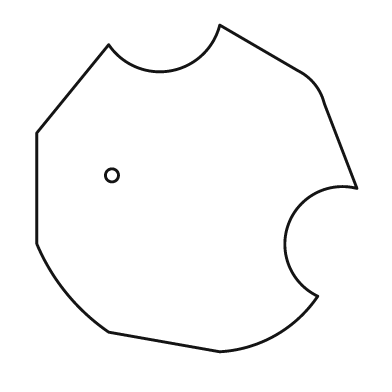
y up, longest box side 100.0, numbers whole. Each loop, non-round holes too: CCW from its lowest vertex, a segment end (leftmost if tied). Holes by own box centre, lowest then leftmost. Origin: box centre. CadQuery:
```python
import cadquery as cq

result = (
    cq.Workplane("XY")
    .moveTo(7.0, -50.0)
    .threePointArc((24.0, -45.0), (37.0, -33.0))
    .threePointArc((28.0, -11.0), (49.0, 0.0))
    .lineTo(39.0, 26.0)
    .threePointArc((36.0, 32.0), (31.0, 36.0))
    .lineTo(7.0, 50.0)
    .threePointArc((-8.0, 36.0), (-27.0, 44.0))
    .lineTo(-49.0, 17.0)
    .lineTo(-49.0, -17.0)
    .threePointArc((-40.0, -32.0), (-27.0, -44.0))
    .close()
    .moveTo(-26.0, 4.0)
    .circle(2.0)
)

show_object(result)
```